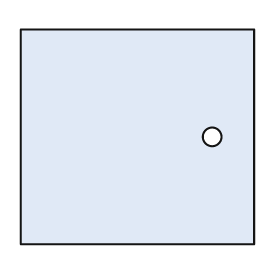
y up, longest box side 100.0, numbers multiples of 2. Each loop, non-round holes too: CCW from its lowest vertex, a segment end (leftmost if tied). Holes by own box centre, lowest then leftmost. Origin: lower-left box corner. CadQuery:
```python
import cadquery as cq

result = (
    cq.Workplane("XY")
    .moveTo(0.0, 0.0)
    .lineTo(100.0, 0.0)
    .lineTo(100.0, 92.0)
    .lineTo(0.0, 92.0)
    .close()
    .moveTo(82.0, 46.0)
    .circle(4.0)
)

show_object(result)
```